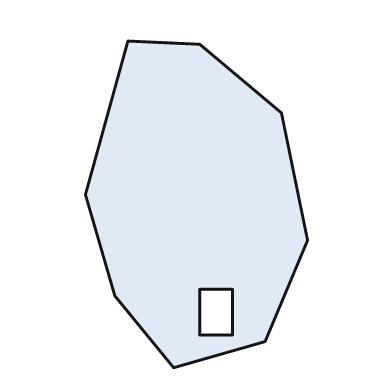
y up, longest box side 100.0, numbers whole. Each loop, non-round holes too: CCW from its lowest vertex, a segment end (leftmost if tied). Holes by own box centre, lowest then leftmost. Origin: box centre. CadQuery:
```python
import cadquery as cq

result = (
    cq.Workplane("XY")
    .moveTo(-7.0, -50.0)
    .lineTo(21.0, -42.0)
    .lineTo(34.0, -11.0)
    .lineTo(26.0, 28.0)
    .lineTo(1.0, 49.0)
    .lineTo(-21.0, 50.0)
    .lineTo(-34.0, 3.0)
    .lineTo(-25.0, -28.0)
    .close()
    .moveTo(1.0, -40.0)
    .lineTo(11.0, -40.0)
    .lineTo(11.0, -26.0)
    .lineTo(1.0, -26.0)
    .close()
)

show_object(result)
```